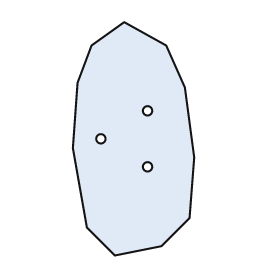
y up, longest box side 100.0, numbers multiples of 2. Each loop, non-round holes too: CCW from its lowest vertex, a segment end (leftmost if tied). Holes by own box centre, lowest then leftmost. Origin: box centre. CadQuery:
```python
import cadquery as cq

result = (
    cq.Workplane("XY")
    .moveTo(-8.0, -50.0)
    .lineTo(12.0, -46.0)
    .lineTo(24.0, -34.0)
    .lineTo(26.0, -8.0)
    .lineTo(22.0, 22.0)
    .lineTo(14.0, 40.0)
    .lineTo(-4.0, 50.0)
    .lineTo(-18.0, 40.0)
    .lineTo(-24.0, 24.0)
    .lineTo(-26.0, -4.0)
    .lineTo(-20.0, -38.0)
    .close()
    .moveTo(6.0, -12.0)
    .circle(2.0)
    .moveTo(-14.0, 0.0)
    .circle(2.0)
    .moveTo(6.0, 12.0)
    .circle(2.0)
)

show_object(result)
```